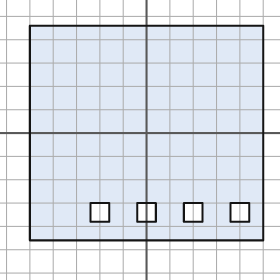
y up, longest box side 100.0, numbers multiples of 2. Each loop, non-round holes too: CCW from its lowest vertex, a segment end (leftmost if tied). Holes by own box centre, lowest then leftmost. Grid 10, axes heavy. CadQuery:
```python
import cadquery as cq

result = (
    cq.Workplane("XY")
    .moveTo(-50.0, -46.0)
    .lineTo(50.0, -46.0)
    .lineTo(50.0, 46.0)
    .lineTo(-50.0, 46.0)
    .close()
    .moveTo(-24.0, -38.0)
    .lineTo(-16.0, -38.0)
    .lineTo(-16.0, -30.0)
    .lineTo(-24.0, -30.0)
    .close()
    .moveTo(-4.0, -38.0)
    .lineTo(4.0, -38.0)
    .lineTo(4.0, -30.0)
    .lineTo(-4.0, -30.0)
    .close()
    .moveTo(16.0, -38.0)
    .lineTo(24.0, -38.0)
    .lineTo(24.0, -30.0)
    .lineTo(16.0, -30.0)
    .close()
    .moveTo(36.0, -38.0)
    .lineTo(44.0, -38.0)
    .lineTo(44.0, -30.0)
    .lineTo(36.0, -30.0)
    .close()
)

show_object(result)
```